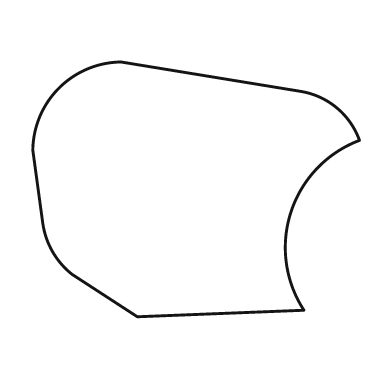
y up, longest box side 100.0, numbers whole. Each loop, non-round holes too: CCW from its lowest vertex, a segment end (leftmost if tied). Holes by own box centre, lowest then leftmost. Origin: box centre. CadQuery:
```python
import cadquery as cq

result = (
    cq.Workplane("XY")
    .moveTo(-18.0, -39.0)
    .lineTo(33.0, -37.0)
    .threePointArc((29.0, -7.0), (50.0, 15.0))
    .threePointArc((43.0, 25.0), (32.0, 30.0))
    .lineTo(-23.0, 39.0)
    .threePointArc((-42.0, 31.0), (-50.0, 12.0))
    .lineTo(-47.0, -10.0)
    .threePointArc((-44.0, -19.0), (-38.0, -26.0))
    .close()
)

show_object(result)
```